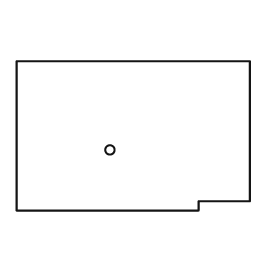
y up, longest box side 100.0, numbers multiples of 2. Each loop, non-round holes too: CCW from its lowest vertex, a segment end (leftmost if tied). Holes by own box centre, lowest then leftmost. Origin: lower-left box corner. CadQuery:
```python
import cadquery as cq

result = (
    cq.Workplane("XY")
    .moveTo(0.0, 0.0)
    .lineTo(78.0, 0.0)
    .lineTo(78.0, 4.0)
    .lineTo(100.0, 4.0)
    .lineTo(100.0, 64.0)
    .lineTo(0.0, 64.0)
    .close()
    .moveTo(40.0, 26.0)
    .circle(2.0)
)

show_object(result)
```